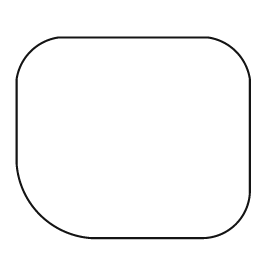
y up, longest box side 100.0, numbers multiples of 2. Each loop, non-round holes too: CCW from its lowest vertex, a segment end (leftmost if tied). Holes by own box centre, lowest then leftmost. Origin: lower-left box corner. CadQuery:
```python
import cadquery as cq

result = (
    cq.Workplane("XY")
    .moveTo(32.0, 0.0)
    .lineTo(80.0, 0.0)
    .threePointArc((94.0, 6.0), (100.0, 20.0))
    .lineTo(100.0, 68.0)
    .threePointArc((94.0, 80.0), (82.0, 86.0))
    .lineTo(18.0, 86.0)
    .threePointArc((6.0, 80.0), (0.0, 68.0))
    .lineTo(0.0, 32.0)
    .threePointArc((10.0, 10.0), (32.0, 0.0))
    .close()
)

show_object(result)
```